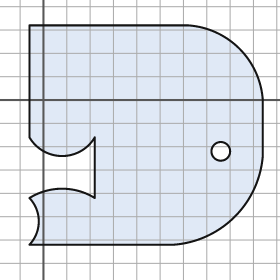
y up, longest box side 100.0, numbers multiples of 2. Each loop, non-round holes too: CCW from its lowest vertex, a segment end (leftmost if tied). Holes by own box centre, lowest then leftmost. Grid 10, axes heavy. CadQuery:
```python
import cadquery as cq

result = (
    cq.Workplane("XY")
    .moveTo(-6.0, -62.0)
    .lineTo(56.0, -62.0)
    .threePointArc((82.0, -50.0), (94.0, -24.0))
    .lineTo(94.0, 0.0)
    .threePointArc((84.0, 22.0), (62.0, 32.0))
    .lineTo(-6.0, 32.0)
    .lineTo(-6.0, -16.0)
    .threePointArc((8.0, -24.0), (22.0, -16.0))
    .lineTo(22.0, -42.0)
    .threePointArc((8.0, -38.0), (-6.0, -42.0))
    .threePointArc((-2.0, -52.0), (-6.0, -62.0))
    .close()
    .moveTo(76.0, -22.0)
    .circle(4.0)
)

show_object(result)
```